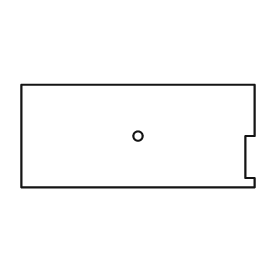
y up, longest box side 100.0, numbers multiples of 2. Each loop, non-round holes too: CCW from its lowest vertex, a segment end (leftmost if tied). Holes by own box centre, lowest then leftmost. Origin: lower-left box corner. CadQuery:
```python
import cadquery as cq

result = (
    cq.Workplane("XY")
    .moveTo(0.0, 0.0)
    .lineTo(100.0, 0.0)
    .lineTo(100.0, 4.0)
    .lineTo(96.0, 4.0)
    .lineTo(96.0, 22.0)
    .lineTo(100.0, 22.0)
    .lineTo(100.0, 44.0)
    .lineTo(0.0, 44.0)
    .close()
    .moveTo(50.0, 22.0)
    .circle(2.0)
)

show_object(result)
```